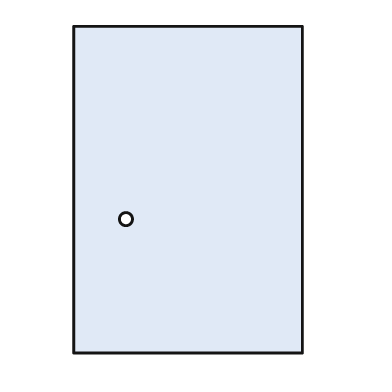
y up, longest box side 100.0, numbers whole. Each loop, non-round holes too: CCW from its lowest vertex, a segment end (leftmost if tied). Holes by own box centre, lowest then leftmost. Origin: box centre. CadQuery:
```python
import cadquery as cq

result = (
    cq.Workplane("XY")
    .moveTo(-35.0, -50.0)
    .lineTo(35.0, -50.0)
    .lineTo(35.0, 50.0)
    .lineTo(-35.0, 50.0)
    .close()
    .moveTo(-19.0, -9.0)
    .circle(2.0)
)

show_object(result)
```